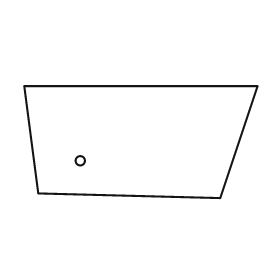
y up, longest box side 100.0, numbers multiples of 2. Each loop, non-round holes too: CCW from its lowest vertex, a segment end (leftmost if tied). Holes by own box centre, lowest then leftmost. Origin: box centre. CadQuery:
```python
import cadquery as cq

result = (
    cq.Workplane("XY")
    .moveTo(34.0, -24.0)
    .lineTo(50.0, 24.0)
    .lineTo(-50.0, 24.0)
    .lineTo(-44.0, -22.0)
    .close()
    .moveTo(-26.0, -8.0)
    .circle(2.0)
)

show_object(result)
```